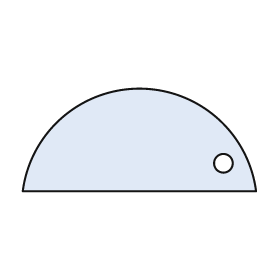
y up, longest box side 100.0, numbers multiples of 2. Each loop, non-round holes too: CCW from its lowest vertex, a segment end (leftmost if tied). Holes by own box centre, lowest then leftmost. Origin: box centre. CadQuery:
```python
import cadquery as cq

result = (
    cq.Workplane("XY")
    .moveTo(-50.0, -22.0)
    .lineTo(50.0, -22.0)
    .threePointArc((0.0, 22.0), (-50.0, -22.0))
    .close()
    .moveTo(36.0, -10.0)
    .circle(4.0)
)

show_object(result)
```